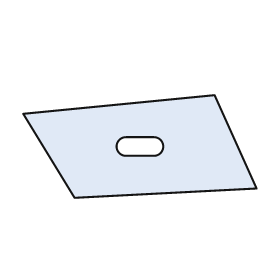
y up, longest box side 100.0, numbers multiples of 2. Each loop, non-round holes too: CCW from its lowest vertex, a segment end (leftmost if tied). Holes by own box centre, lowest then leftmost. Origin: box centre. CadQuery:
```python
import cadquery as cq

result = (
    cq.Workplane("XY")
    .moveTo(-28.0, -22.0)
    .lineTo(50.0, -18.0)
    .lineTo(32.0, 22.0)
    .lineTo(-50.0, 14.0)
    .close()
    .moveTo(-6.0, -4.0)
    .lineTo(6.0, -4.0)
    .threePointArc((10.0, 0.0), (6.0, 4.0))
    .lineTo(-6.0, 4.0)
    .threePointArc((-10.0, 0.0), (-6.0, -4.0))
    .close()
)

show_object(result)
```